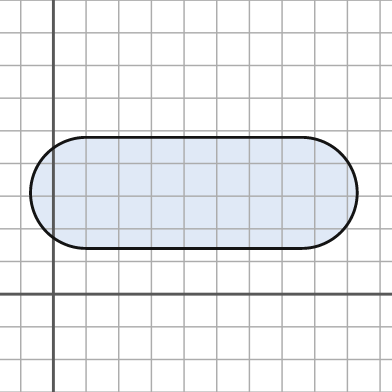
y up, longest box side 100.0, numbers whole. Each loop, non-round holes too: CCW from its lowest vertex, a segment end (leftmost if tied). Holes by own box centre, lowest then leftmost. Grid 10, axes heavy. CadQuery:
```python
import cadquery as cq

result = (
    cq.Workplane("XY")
    .moveTo(10.0, 14.0)
    .lineTo(76.0, 14.0)
    .threePointArc((93.0, 31.0), (76.0, 48.0))
    .lineTo(10.0, 48.0)
    .threePointArc((-7.0, 31.0), (10.0, 14.0))
    .close()
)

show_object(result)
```